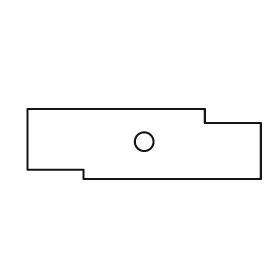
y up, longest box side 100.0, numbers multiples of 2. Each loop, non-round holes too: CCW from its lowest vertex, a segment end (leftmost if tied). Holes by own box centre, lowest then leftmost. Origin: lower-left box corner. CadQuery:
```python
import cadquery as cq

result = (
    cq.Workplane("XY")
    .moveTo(24.0, 0.0)
    .lineTo(100.0, 0.0)
    .lineTo(100.0, 24.0)
    .lineTo(76.0, 24.0)
    .lineTo(76.0, 30.0)
    .lineTo(0.0, 30.0)
    .lineTo(0.0, 4.0)
    .lineTo(24.0, 4.0)
    .close()
    .moveTo(50.0, 16.0)
    .circle(4.0)
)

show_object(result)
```